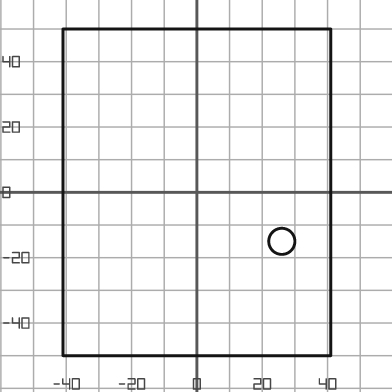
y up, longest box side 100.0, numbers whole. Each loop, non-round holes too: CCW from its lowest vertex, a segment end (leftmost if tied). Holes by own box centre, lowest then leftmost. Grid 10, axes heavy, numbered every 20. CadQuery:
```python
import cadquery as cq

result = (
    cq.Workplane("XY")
    .moveTo(-41.0, -50.0)
    .lineTo(41.0, -50.0)
    .lineTo(41.0, 50.0)
    .lineTo(-41.0, 50.0)
    .close()
    .moveTo(26.0, -15.0)
    .circle(4.0)
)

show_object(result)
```